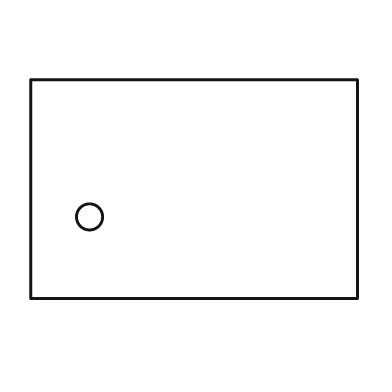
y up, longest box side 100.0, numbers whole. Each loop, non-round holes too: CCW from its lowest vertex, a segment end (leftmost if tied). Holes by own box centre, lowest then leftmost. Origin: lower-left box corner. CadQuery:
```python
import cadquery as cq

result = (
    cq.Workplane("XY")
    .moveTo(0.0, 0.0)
    .lineTo(100.0, 0.0)
    .lineTo(100.0, 67.0)
    .lineTo(0.0, 67.0)
    .close()
    .moveTo(18.0, 25.0)
    .circle(4.0)
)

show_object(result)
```